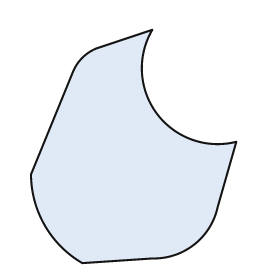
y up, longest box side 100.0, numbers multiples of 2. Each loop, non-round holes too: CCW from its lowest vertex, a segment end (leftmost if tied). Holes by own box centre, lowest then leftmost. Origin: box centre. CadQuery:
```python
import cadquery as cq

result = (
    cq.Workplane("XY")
    .moveTo(-22.0, -50.0)
    .lineTo(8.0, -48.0)
    .threePointArc((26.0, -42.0), (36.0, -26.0))
    .lineTo(44.0, 2.0)
    .threePointArc((10.0, 14.0), (8.0, 50.0))
    .lineTo(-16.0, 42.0)
    .threePointArc((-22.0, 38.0), (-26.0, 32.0))
    .lineTo(-44.0, -12.0)
    .threePointArc((-38.0, -34.0), (-22.0, -50.0))
    .close()
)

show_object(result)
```